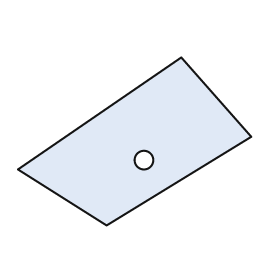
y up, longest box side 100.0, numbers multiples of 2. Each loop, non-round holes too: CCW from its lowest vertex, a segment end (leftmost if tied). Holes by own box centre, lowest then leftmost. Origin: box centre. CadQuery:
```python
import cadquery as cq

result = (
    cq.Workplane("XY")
    .moveTo(-12.0, -36.0)
    .lineTo(50.0, 2.0)
    .lineTo(20.0, 36.0)
    .lineTo(-50.0, -12.0)
    .close()
    .moveTo(4.0, -8.0)
    .circle(4.0)
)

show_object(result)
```